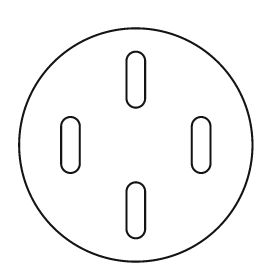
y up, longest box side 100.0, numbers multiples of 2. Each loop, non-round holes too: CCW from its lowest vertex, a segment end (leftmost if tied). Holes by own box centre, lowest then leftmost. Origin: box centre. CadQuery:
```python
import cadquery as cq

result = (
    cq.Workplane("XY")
    .moveTo(0.0, 0.0)
    .circle(50.0)
    .moveTo(-4.0, -36.0)
    .threePointArc((0.0, -40.0), (4.0, -36.0))
    .lineTo(4.0, -20.0)
    .threePointArc((0.0, -16.0), (-4.0, -20.0))
    .close()
    .moveTo(-32.0, -8.0)
    .threePointArc((-28.0, -12.0), (-24.0, -8.0))
    .lineTo(-24.0, 8.0)
    .threePointArc((-28.0, 12.0), (-32.0, 8.0))
    .close()
    .moveTo(24.0, -8.0)
    .threePointArc((28.0, -12.0), (32.0, -8.0))
    .lineTo(32.0, 8.0)
    .threePointArc((28.0, 12.0), (24.0, 8.0))
    .close()
    .moveTo(-4.0, 20.0)
    .threePointArc((0.0, 16.0), (4.0, 20.0))
    .lineTo(4.0, 36.0)
    .threePointArc((0.0, 40.0), (-4.0, 36.0))
    .close()
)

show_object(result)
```